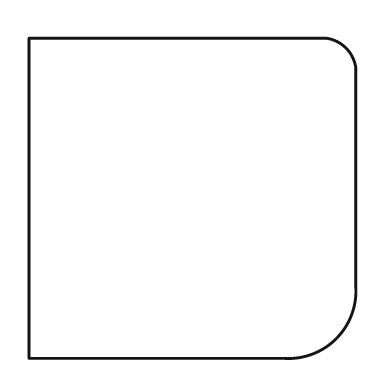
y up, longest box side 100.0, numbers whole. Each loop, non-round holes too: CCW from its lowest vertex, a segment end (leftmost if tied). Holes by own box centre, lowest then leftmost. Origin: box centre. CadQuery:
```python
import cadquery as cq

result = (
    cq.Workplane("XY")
    .moveTo(-50.0, -49.0)
    .lineTo(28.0, -49.0)
    .threePointArc((44.0, -43.0), (50.0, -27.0))
    .lineTo(50.0, 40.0)
    .threePointArc((47.0, 46.0), (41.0, 49.0))
    .lineTo(-50.0, 49.0)
    .close()
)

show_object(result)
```